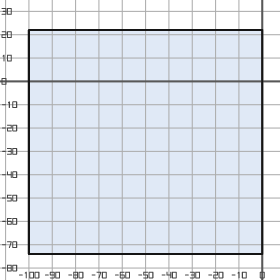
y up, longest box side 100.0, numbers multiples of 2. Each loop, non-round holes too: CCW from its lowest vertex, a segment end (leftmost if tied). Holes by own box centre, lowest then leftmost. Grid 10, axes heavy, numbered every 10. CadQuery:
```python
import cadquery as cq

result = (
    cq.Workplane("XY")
    .moveTo(-100.0, -74.0)
    .lineTo(0.0, -74.0)
    .lineTo(0.0, 22.0)
    .lineTo(-100.0, 22.0)
    .close()
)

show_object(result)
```